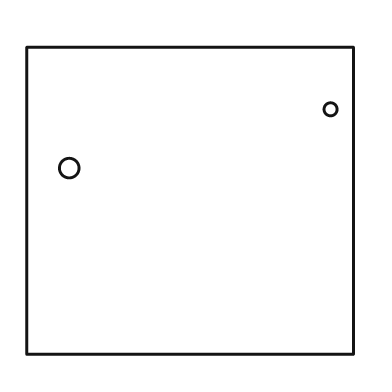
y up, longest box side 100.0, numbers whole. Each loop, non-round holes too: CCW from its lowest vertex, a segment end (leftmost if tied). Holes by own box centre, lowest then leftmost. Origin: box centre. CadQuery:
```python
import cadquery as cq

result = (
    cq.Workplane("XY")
    .moveTo(-50.0, -47.0)
    .lineTo(50.0, -47.0)
    .lineTo(50.0, 47.0)
    .lineTo(-50.0, 47.0)
    .close()
    .moveTo(-37.0, 10.0)
    .circle(3.0)
    .moveTo(43.0, 28.0)
    .circle(2.0)
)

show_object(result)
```